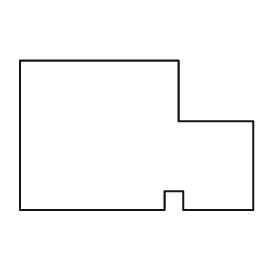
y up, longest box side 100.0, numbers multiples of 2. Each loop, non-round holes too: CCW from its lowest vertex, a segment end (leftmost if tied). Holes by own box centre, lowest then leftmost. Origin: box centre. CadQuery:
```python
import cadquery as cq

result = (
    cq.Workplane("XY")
    .moveTo(-50.0, -32.0)
    .lineTo(12.0, -32.0)
    .lineTo(12.0, -24.0)
    .lineTo(20.0, -24.0)
    .lineTo(20.0, -32.0)
    .lineTo(50.0, -32.0)
    .lineTo(50.0, 6.0)
    .lineTo(18.0, 6.0)
    .lineTo(18.0, 32.0)
    .lineTo(-50.0, 32.0)
    .close()
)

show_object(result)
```